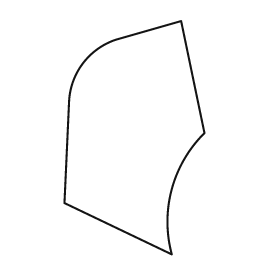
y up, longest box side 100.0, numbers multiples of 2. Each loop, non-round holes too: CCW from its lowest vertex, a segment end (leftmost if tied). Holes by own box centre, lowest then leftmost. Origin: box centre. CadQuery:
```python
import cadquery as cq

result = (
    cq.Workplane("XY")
    .moveTo(16.0, -50.0)
    .threePointArc((16.0, -22.0), (30.0, 2.0))
    .lineTo(20.0, 50.0)
    .lineTo(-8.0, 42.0)
    .threePointArc((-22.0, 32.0), (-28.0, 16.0))
    .lineTo(-30.0, -28.0)
    .close()
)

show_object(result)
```